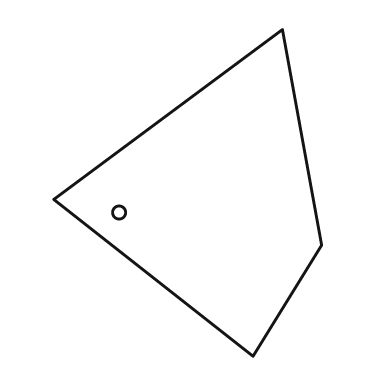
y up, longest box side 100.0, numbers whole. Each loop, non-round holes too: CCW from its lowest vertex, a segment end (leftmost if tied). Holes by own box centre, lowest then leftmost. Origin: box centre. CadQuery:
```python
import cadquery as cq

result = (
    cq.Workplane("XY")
    .moveTo(20.0, -50.0)
    .lineTo(41.0, -16.0)
    .lineTo(29.0, 50.0)
    .lineTo(-41.0, -2.0)
    .close()
    .moveTo(-21.0, -6.0)
    .circle(2.0)
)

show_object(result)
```